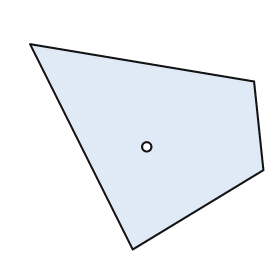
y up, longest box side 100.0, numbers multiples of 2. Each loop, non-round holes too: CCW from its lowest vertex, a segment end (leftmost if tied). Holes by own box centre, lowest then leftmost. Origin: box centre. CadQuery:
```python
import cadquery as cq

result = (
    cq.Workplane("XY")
    .moveTo(-6.0, -44.0)
    .lineTo(50.0, -10.0)
    .lineTo(46.0, 28.0)
    .lineTo(-50.0, 44.0)
    .close()
    .moveTo(0.0, 0.0)
    .circle(2.0)
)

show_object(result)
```